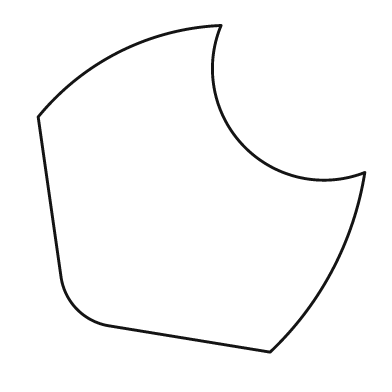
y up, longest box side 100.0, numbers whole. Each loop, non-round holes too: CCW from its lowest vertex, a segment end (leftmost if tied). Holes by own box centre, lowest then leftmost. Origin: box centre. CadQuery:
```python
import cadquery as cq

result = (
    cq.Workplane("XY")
    .moveTo(21.0, -50.0)
    .threePointArc((40.0, -25.0), (50.0, 5.0))
    .threePointArc((13.0, 13.0), (6.0, 50.0))
    .threePointArc((-25.0, 42.0), (-50.0, 22.0))
    .lineTo(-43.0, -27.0)
    .threePointArc((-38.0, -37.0), (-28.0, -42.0))
    .close()
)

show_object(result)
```